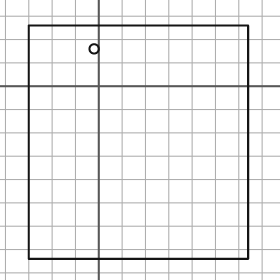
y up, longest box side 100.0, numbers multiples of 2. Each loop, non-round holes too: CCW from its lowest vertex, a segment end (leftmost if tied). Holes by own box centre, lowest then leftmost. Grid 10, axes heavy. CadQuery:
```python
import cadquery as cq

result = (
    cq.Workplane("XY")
    .moveTo(-30.0, -74.0)
    .lineTo(64.0, -74.0)
    .lineTo(64.0, 26.0)
    .lineTo(-30.0, 26.0)
    .close()
    .moveTo(-2.0, 16.0)
    .circle(2.0)
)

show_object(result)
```